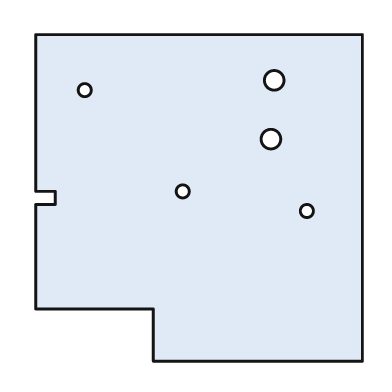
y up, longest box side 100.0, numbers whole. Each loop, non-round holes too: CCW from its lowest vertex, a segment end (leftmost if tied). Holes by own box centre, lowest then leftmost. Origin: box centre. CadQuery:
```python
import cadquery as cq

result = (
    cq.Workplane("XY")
    .moveTo(-14.0, -50.0)
    .lineTo(50.0, -50.0)
    .lineTo(50.0, 50.0)
    .lineTo(-50.0, 50.0)
    .lineTo(-50.0, 2.0)
    .lineTo(-44.0, 2.0)
    .lineTo(-44.0, -2.0)
    .lineTo(-50.0, -2.0)
    .lineTo(-50.0, -34.0)
    .lineTo(-14.0, -34.0)
    .close()
    .moveTo(33.0, -4.0)
    .circle(2.0)
    .moveTo(-5.0, 2.0)
    .circle(2.0)
    .moveTo(22.0, 18.0)
    .circle(3.0)
    .moveTo(-35.0, 33.0)
    .circle(2.0)
    .moveTo(23.0, 36.0)
    .circle(3.0)
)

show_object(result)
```